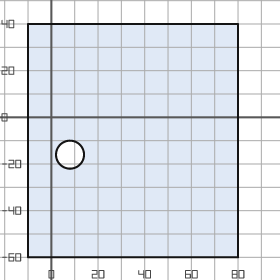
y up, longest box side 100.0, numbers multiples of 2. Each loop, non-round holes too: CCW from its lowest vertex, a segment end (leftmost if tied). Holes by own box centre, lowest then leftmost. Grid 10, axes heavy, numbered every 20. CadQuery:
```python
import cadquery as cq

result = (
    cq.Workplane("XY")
    .moveTo(-10.0, -60.0)
    .lineTo(80.0, -60.0)
    .lineTo(80.0, 40.0)
    .lineTo(-10.0, 40.0)
    .close()
    .moveTo(8.0, -16.0)
    .circle(6.0)
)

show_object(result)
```